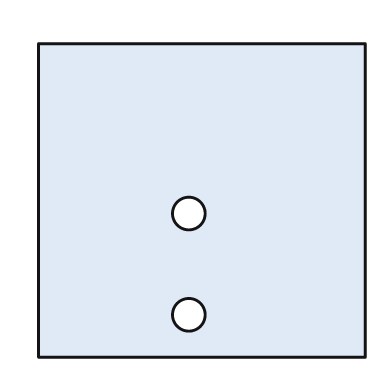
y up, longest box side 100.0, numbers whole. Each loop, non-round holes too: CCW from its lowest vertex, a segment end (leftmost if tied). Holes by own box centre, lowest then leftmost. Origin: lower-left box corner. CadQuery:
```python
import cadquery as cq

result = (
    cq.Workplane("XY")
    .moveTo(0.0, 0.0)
    .lineTo(100.0, 0.0)
    .lineTo(100.0, 96.0)
    .lineTo(0.0, 96.0)
    .close()
    .moveTo(46.0, 13.0)
    .circle(5.0)
    .moveTo(46.0, 44.0)
    .circle(5.0)
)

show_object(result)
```